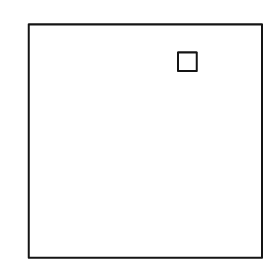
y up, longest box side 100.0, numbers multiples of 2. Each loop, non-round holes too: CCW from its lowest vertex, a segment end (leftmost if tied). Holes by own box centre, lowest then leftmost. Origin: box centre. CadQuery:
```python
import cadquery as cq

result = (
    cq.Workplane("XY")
    .moveTo(-50.0, -50.0)
    .lineTo(50.0, -50.0)
    .lineTo(50.0, 50.0)
    .lineTo(-50.0, 50.0)
    .close()
    .moveTo(14.0, 30.0)
    .lineTo(22.0, 30.0)
    .lineTo(22.0, 38.0)
    .lineTo(14.0, 38.0)
    .close()
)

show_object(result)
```